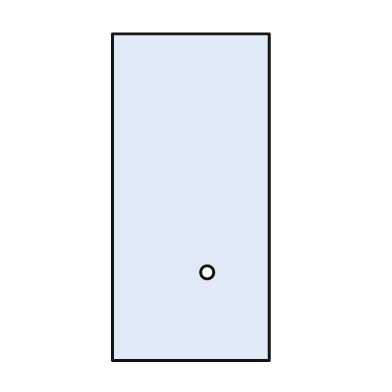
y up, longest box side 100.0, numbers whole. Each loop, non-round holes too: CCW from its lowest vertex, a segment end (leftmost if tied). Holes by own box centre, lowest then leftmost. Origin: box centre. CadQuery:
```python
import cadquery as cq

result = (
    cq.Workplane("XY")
    .moveTo(-24.0, -50.0)
    .lineTo(24.0, -50.0)
    .lineTo(24.0, 50.0)
    .lineTo(-24.0, 50.0)
    .close()
    .moveTo(5.0, -23.0)
    .circle(2.0)
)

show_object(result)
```